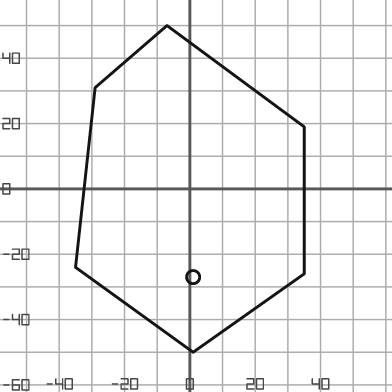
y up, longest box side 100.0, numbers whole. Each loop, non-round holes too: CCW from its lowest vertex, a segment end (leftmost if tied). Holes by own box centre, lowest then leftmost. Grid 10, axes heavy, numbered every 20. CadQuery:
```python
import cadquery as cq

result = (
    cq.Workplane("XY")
    .moveTo(1.0, -50.0)
    .lineTo(35.0, -26.0)
    .lineTo(35.0, 19.0)
    .lineTo(-7.0, 50.0)
    .lineTo(-29.0, 31.0)
    .lineTo(-35.0, -24.0)
    .close()
    .moveTo(1.0, -27.0)
    .circle(2.0)
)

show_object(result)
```